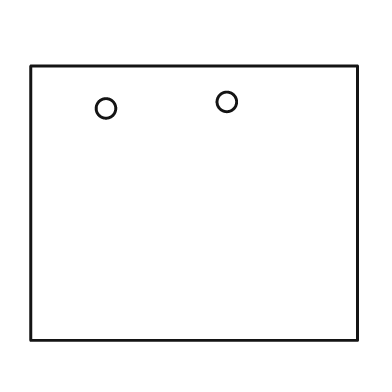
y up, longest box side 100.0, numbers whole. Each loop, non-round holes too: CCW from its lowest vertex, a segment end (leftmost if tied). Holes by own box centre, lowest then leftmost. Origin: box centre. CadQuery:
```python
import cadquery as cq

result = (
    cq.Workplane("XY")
    .moveTo(-50.0, -42.0)
    .lineTo(50.0, -42.0)
    .lineTo(50.0, 42.0)
    .lineTo(-50.0, 42.0)
    .close()
    .moveTo(-27.0, 29.0)
    .circle(3.0)
    .moveTo(10.0, 31.0)
    .circle(3.0)
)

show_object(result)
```